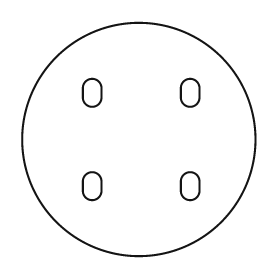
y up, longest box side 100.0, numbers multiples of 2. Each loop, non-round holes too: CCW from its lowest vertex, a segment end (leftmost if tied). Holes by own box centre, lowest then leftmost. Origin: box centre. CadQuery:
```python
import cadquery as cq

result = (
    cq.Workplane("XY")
    .moveTo(0.0, 0.0)
    .circle(50.0)
    .moveTo(-24.0, -22.0)
    .threePointArc((-20.0, -26.0), (-16.0, -22.0))
    .lineTo(-16.0, -18.0)
    .threePointArc((-20.0, -14.0), (-24.0, -18.0))
    .close()
    .moveTo(18.0, -22.0)
    .threePointArc((22.0, -26.0), (26.0, -22.0))
    .lineTo(26.0, -18.0)
    .threePointArc((22.0, -14.0), (18.0, -18.0))
    .close()
    .moveTo(-24.0, 18.0)
    .threePointArc((-20.0, 14.0), (-16.0, 18.0))
    .lineTo(-16.0, 22.0)
    .threePointArc((-20.0, 26.0), (-24.0, 22.0))
    .close()
    .moveTo(18.0, 18.0)
    .threePointArc((22.0, 14.0), (26.0, 18.0))
    .lineTo(26.0, 22.0)
    .threePointArc((22.0, 26.0), (18.0, 22.0))
    .close()
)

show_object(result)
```